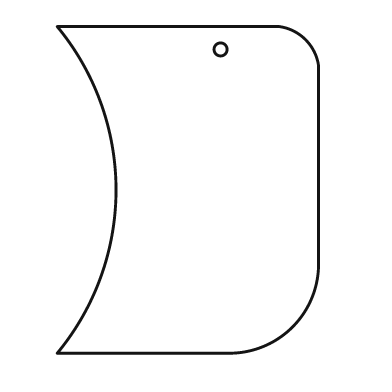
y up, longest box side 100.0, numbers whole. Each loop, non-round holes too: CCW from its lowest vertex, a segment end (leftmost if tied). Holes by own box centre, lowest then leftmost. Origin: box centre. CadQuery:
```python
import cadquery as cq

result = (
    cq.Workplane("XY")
    .moveTo(-40.0, -50.0)
    .lineTo(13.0, -50.0)
    .threePointArc((32.0, -42.0), (40.0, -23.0))
    .lineTo(40.0, 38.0)
    .threePointArc((36.0, 46.0), (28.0, 50.0))
    .lineTo(-40.0, 50.0)
    .threePointArc((-22.0, 0.0), (-40.0, -50.0))
    .close()
    .moveTo(10.0, 43.0)
    .circle(2.0)
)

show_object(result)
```